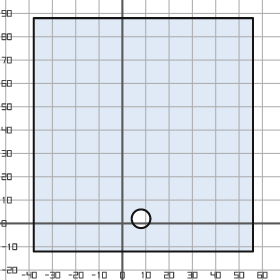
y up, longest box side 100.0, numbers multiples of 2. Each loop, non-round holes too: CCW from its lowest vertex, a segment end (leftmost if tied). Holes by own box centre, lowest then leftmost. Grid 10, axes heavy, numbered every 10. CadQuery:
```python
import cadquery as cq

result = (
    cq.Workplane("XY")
    .moveTo(-38.0, -12.0)
    .lineTo(56.0, -12.0)
    .lineTo(56.0, 88.0)
    .lineTo(-38.0, 88.0)
    .close()
    .moveTo(8.0, 2.0)
    .circle(4.0)
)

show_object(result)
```